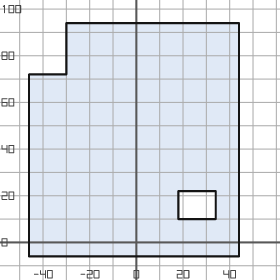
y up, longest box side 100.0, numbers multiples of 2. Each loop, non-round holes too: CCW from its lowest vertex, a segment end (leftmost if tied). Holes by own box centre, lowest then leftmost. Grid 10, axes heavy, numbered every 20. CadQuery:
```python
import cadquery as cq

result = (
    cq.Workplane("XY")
    .moveTo(-46.0, -6.0)
    .lineTo(44.0, -6.0)
    .lineTo(44.0, 94.0)
    .lineTo(-30.0, 94.0)
    .lineTo(-30.0, 72.0)
    .lineTo(-46.0, 72.0)
    .close()
    .moveTo(18.0, 10.0)
    .lineTo(34.0, 10.0)
    .lineTo(34.0, 22.0)
    .lineTo(18.0, 22.0)
    .close()
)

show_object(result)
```